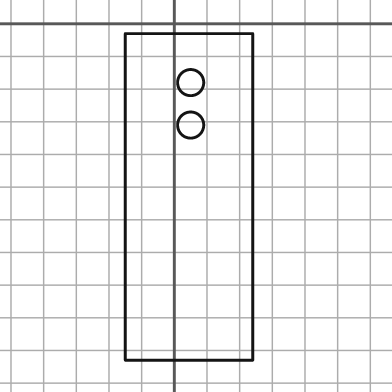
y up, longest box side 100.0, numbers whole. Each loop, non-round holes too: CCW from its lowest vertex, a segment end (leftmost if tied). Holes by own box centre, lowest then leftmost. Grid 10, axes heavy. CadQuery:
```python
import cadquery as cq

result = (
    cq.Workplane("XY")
    .moveTo(-15.0, -103.0)
    .lineTo(24.0, -103.0)
    .lineTo(24.0, -3.0)
    .lineTo(-15.0, -3.0)
    .close()
    .moveTo(5.0, -31.0)
    .circle(4.0)
    .moveTo(5.0, -18.0)
    .circle(4.0)
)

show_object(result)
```